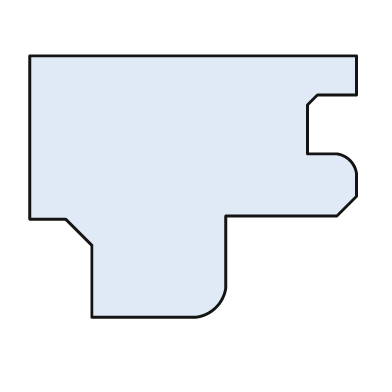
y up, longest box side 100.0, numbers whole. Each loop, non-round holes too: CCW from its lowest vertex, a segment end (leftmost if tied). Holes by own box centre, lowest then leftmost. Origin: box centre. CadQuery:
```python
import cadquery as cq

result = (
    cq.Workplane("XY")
    .moveTo(-31.0, -40.0)
    .lineTo(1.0, -40.0)
    .threePointArc((7.0, -37.0), (10.0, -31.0))
    .lineTo(10.0, -9.0)
    .lineTo(44.0, -9.0)
    .lineTo(50.0, -3.0)
    .lineTo(50.0, 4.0)
    .threePointArc((48.0, 8.0), (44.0, 10.0))
    .lineTo(35.0, 10.0)
    .lineTo(35.0, 25.0)
    .lineTo(38.0, 28.0)
    .lineTo(50.0, 28.0)
    .lineTo(50.0, 40.0)
    .lineTo(-50.0, 40.0)
    .lineTo(-50.0, -10.0)
    .lineTo(-39.0, -10.0)
    .lineTo(-31.0, -18.0)
    .close()
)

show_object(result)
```